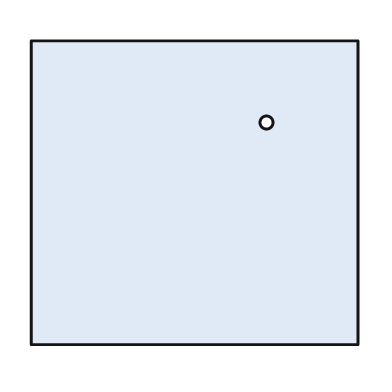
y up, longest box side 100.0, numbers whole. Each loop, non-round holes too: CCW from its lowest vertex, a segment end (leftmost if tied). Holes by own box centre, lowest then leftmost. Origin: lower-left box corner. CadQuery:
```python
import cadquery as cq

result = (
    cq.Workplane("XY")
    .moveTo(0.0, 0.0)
    .lineTo(100.0, 0.0)
    .lineTo(100.0, 93.0)
    .lineTo(0.0, 93.0)
    .close()
    .moveTo(72.0, 68.0)
    .circle(2.0)
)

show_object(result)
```